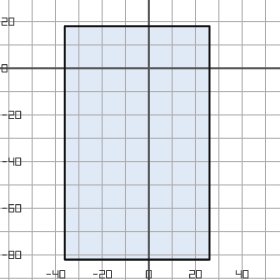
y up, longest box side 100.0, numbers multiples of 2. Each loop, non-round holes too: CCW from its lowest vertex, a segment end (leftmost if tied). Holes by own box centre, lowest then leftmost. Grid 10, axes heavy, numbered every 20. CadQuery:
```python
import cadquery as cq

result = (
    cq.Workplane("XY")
    .moveTo(-36.0, -82.0)
    .lineTo(26.0, -82.0)
    .lineTo(26.0, 18.0)
    .lineTo(-36.0, 18.0)
    .close()
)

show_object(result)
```